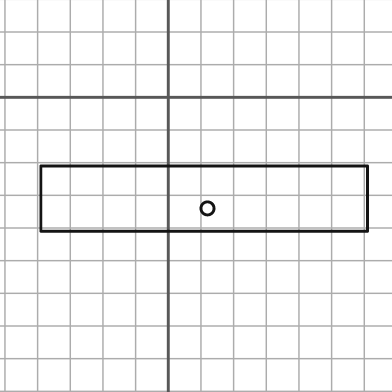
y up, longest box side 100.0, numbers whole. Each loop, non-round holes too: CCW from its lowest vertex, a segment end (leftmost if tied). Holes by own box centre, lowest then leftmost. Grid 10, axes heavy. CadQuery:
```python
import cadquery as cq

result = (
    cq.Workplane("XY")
    .moveTo(-39.0, -41.0)
    .lineTo(61.0, -41.0)
    .lineTo(61.0, -21.0)
    .lineTo(-39.0, -21.0)
    .close()
    .moveTo(12.0, -34.0)
    .circle(2.0)
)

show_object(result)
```